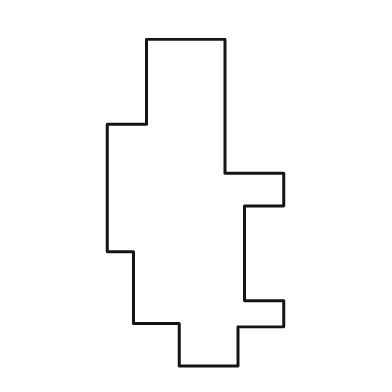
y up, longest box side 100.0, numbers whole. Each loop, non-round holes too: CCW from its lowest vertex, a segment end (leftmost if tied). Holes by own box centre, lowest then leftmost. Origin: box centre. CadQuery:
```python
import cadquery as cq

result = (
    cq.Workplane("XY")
    .moveTo(-5.0, -50.0)
    .lineTo(13.0, -50.0)
    .lineTo(13.0, -38.0)
    .lineTo(27.0, -38.0)
    .lineTo(27.0, -30.0)
    .lineTo(15.0, -30.0)
    .lineTo(15.0, -1.0)
    .lineTo(27.0, -1.0)
    .lineTo(27.0, 9.0)
    .lineTo(9.0, 9.0)
    .lineTo(9.0, 50.0)
    .lineTo(-15.0, 50.0)
    .lineTo(-15.0, 24.0)
    .lineTo(-27.0, 24.0)
    .lineTo(-27.0, -15.0)
    .lineTo(-19.0, -15.0)
    .lineTo(-19.0, -37.0)
    .lineTo(-5.0, -37.0)
    .close()
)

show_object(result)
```